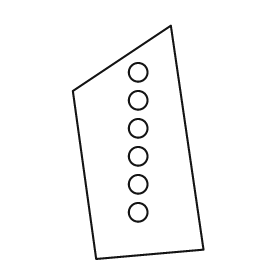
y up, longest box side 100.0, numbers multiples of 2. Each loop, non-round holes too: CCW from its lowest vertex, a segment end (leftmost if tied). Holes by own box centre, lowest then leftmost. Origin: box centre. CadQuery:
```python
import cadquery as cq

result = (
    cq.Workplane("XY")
    .moveTo(-18.0, -50.0)
    .lineTo(28.0, -46.0)
    .lineTo(14.0, 50.0)
    .lineTo(-28.0, 22.0)
    .close()
    .moveTo(0.0, -30.0)
    .circle(4.0)
    .moveTo(0.0, -18.0)
    .circle(4.0)
    .moveTo(0.0, -6.0)
    .circle(4.0)
    .moveTo(0.0, 6.0)
    .circle(4.0)
    .moveTo(0.0, 18.0)
    .circle(4.0)
    .moveTo(0.0, 30.0)
    .circle(4.0)
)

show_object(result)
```